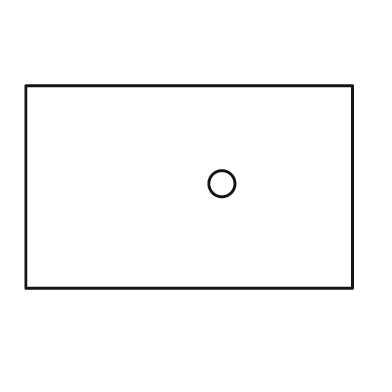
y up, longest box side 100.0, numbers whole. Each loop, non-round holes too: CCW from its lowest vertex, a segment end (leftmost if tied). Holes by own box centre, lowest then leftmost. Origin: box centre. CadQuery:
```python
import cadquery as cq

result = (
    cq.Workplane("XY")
    .moveTo(-50.0, -31.0)
    .lineTo(50.0, -31.0)
    .lineTo(50.0, 31.0)
    .lineTo(-50.0, 31.0)
    .close()
    .moveTo(10.0, 1.0)
    .circle(4.0)
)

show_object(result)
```